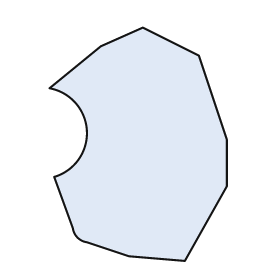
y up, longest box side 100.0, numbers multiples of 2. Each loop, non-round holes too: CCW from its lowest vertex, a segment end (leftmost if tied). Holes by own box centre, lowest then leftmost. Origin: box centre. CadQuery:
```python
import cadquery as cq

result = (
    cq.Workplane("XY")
    .moveTo(20.0, -50.0)
    .lineTo(38.0, -18.0)
    .lineTo(38.0, 2.0)
    .lineTo(26.0, 38.0)
    .lineTo(2.0, 50.0)
    .lineTo(-16.0, 42.0)
    .lineTo(-38.0, 24.0)
    .threePointArc((-22.0, 6.0), (-36.0, -14.0))
    .lineTo(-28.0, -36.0)
    .threePointArc((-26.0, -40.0), (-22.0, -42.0))
    .lineTo(-4.0, -48.0)
    .close()
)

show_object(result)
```